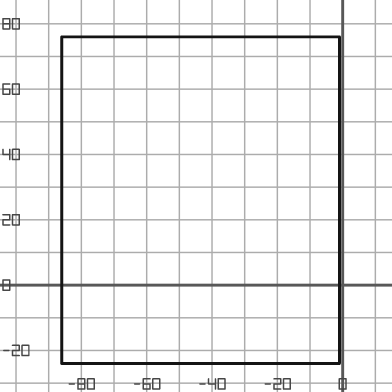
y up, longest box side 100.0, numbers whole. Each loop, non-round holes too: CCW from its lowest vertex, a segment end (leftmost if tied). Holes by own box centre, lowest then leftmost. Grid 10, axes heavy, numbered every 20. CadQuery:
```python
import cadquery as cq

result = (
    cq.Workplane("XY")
    .moveTo(-86.0, -24.0)
    .lineTo(-1.0, -24.0)
    .lineTo(-1.0, 76.0)
    .lineTo(-86.0, 76.0)
    .close()
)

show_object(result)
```